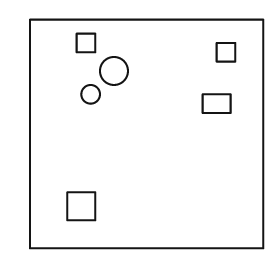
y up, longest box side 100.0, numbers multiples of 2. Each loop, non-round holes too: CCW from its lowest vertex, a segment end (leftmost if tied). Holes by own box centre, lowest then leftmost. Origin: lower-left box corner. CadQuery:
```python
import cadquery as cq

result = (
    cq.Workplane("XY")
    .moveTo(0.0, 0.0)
    .lineTo(100.0, 0.0)
    .lineTo(100.0, 98.0)
    .lineTo(0.0, 98.0)
    .close()
    .moveTo(16.0, 12.0)
    .lineTo(28.0, 12.0)
    .lineTo(28.0, 24.0)
    .lineTo(16.0, 24.0)
    .close()
    .moveTo(74.0, 58.0)
    .lineTo(86.0, 58.0)
    .lineTo(86.0, 66.0)
    .lineTo(74.0, 66.0)
    .close()
    .moveTo(26.0, 66.0)
    .circle(4.0)
    .moveTo(36.0, 76.0)
    .circle(6.0)
    .moveTo(80.0, 80.0)
    .lineTo(88.0, 80.0)
    .lineTo(88.0, 88.0)
    .lineTo(80.0, 88.0)
    .close()
    .moveTo(20.0, 84.0)
    .lineTo(28.0, 84.0)
    .lineTo(28.0, 92.0)
    .lineTo(20.0, 92.0)
    .close()
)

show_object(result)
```